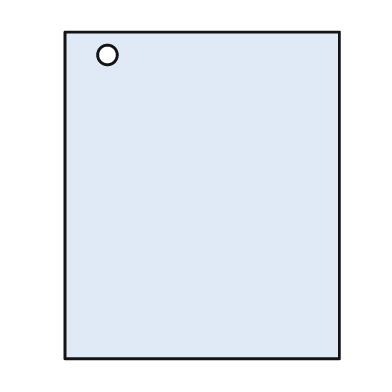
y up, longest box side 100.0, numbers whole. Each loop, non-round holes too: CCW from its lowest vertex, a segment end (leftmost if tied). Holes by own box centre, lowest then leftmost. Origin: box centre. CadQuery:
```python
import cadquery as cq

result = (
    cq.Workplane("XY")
    .moveTo(-42.0, -50.0)
    .lineTo(42.0, -50.0)
    .lineTo(42.0, 50.0)
    .lineTo(-42.0, 50.0)
    .close()
    .moveTo(-29.0, 43.0)
    .circle(3.0)
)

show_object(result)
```